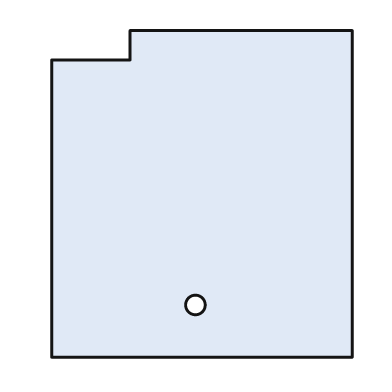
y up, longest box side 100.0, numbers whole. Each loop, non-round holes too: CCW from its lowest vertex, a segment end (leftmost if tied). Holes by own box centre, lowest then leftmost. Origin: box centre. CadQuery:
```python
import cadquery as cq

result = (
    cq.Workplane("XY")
    .moveTo(-46.0, -50.0)
    .lineTo(46.0, -50.0)
    .lineTo(46.0, 50.0)
    .lineTo(-22.0, 50.0)
    .lineTo(-22.0, 41.0)
    .lineTo(-46.0, 41.0)
    .close()
    .moveTo(-2.0, -34.0)
    .circle(3.0)
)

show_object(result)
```